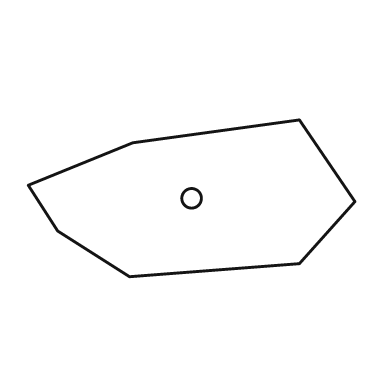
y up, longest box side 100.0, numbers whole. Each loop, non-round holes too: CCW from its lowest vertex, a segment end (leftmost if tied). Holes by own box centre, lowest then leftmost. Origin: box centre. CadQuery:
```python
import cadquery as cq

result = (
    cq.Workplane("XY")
    .moveTo(-19.0, -24.0)
    .lineTo(33.0, -20.0)
    .lineTo(50.0, -1.0)
    .lineTo(33.0, 24.0)
    .lineTo(-18.0, 17.0)
    .lineTo(-50.0, 4.0)
    .lineTo(-41.0, -10.0)
    .close()
    .moveTo(0.0, 0.0)
    .circle(3.0)
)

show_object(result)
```